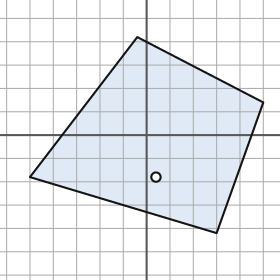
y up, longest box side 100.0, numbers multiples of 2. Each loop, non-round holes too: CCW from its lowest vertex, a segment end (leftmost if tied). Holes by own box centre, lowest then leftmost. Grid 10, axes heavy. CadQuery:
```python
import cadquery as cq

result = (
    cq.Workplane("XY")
    .moveTo(30.0, -42.0)
    .lineTo(50.0, 14.0)
    .lineTo(-4.0, 42.0)
    .lineTo(-50.0, -18.0)
    .close()
    .moveTo(4.0, -18.0)
    .circle(2.0)
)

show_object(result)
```